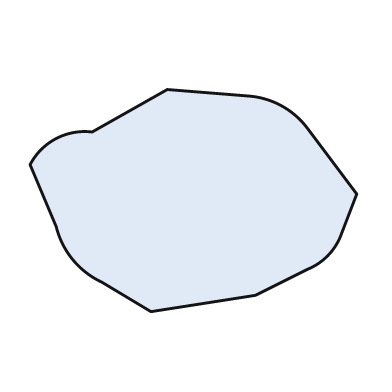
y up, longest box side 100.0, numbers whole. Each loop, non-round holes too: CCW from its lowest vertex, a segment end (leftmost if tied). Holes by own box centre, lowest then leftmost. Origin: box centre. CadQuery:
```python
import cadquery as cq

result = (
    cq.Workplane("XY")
    .moveTo(-13.0, -34.0)
    .lineTo(19.0, -29.0)
    .lineTo(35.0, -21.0)
    .threePointArc((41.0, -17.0), (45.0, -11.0))
    .lineTo(50.0, 2.0)
    .lineTo(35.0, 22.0)
    .threePointArc((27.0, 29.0), (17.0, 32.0))
    .lineTo(-8.0, 34.0)
    .lineTo(-31.0, 21.0)
    .threePointArc((-42.0, 19.0), (-50.0, 11.0))
    .lineTo(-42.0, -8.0)
    .threePointArc((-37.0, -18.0), (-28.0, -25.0))
    .close()
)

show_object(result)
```